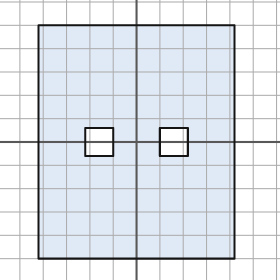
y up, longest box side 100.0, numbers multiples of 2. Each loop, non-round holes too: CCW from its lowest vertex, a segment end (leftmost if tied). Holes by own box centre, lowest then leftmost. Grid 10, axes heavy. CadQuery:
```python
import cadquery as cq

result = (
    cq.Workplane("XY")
    .moveTo(-42.0, -50.0)
    .lineTo(42.0, -50.0)
    .lineTo(42.0, 50.0)
    .lineTo(-42.0, 50.0)
    .close()
    .moveTo(-22.0, -6.0)
    .lineTo(-10.0, -6.0)
    .lineTo(-10.0, 6.0)
    .lineTo(-22.0, 6.0)
    .close()
    .moveTo(10.0, -6.0)
    .lineTo(22.0, -6.0)
    .lineTo(22.0, 6.0)
    .lineTo(10.0, 6.0)
    .close()
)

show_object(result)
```